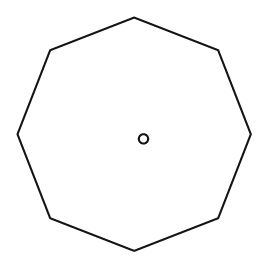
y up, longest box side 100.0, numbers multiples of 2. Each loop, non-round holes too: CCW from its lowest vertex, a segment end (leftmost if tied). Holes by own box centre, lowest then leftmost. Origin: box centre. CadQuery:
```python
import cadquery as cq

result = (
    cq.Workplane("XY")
    .moveTo(0.0, -50.0)
    .lineTo(36.0, -36.0)
    .lineTo(50.0, 0.0)
    .lineTo(36.0, 36.0)
    .lineTo(0.0, 50.0)
    .lineTo(-36.0, 36.0)
    .lineTo(-50.0, 0.0)
    .lineTo(-36.0, -36.0)
    .close()
    .moveTo(4.0, -2.0)
    .circle(2.0)
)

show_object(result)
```